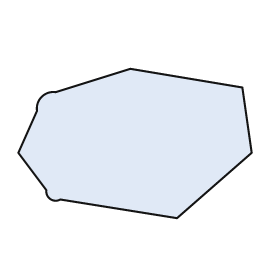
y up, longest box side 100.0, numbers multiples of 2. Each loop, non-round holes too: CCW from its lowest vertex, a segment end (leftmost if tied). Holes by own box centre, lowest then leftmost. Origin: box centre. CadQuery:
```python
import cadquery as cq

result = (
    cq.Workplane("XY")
    .moveTo(18.0, -32.0)
    .lineTo(50.0, -4.0)
    .lineTo(46.0, 24.0)
    .lineTo(-2.0, 32.0)
    .lineTo(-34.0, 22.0)
    .threePointArc((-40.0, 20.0), (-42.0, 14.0))
    .lineTo(-50.0, -4.0)
    .lineTo(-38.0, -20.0)
    .threePointArc((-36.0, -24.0), (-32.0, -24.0))
    .close()
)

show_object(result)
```